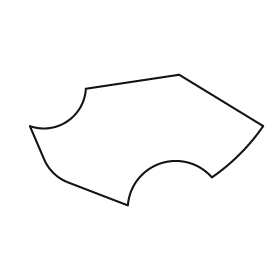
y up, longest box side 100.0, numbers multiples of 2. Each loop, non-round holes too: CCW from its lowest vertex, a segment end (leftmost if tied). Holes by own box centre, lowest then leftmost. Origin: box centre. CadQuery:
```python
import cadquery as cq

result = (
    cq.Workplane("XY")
    .moveTo(-8.0, -28.0)
    .threePointArc((6.0, -10.0), (28.0, -16.0))
    .threePointArc((40.0, -6.0), (50.0, 6.0))
    .lineTo(14.0, 28.0)
    .lineTo(-26.0, 22.0)
    .threePointArc((-34.0, 8.0), (-50.0, 6.0))
    .lineTo(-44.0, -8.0)
    .threePointArc((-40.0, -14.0), (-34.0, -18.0))
    .close()
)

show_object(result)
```